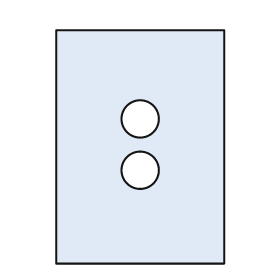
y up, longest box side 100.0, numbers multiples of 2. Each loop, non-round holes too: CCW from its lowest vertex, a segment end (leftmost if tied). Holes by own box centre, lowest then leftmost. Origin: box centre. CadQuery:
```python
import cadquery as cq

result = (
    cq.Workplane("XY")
    .moveTo(-36.0, -50.0)
    .lineTo(36.0, -50.0)
    .lineTo(36.0, 50.0)
    .lineTo(-36.0, 50.0)
    .close()
    .moveTo(0.0, -10.0)
    .circle(8.0)
    .moveTo(0.0, 12.0)
    .circle(8.0)
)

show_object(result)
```